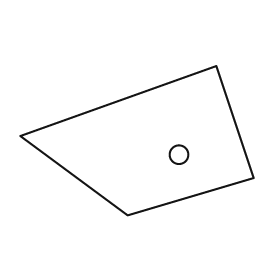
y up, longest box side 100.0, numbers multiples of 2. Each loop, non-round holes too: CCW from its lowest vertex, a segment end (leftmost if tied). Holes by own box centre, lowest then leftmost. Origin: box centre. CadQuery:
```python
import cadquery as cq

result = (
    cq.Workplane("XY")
    .moveTo(-4.0, -32.0)
    .lineTo(50.0, -16.0)
    .lineTo(34.0, 32.0)
    .lineTo(-50.0, 2.0)
    .close()
    .moveTo(18.0, -6.0)
    .circle(4.0)
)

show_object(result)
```